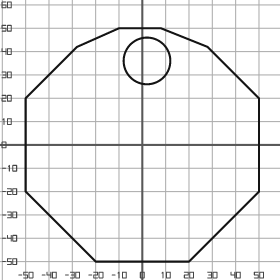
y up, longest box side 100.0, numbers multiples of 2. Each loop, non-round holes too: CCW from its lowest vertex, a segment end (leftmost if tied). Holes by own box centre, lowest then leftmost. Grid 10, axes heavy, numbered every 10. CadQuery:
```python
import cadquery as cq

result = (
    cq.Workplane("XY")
    .moveTo(-20.0, -50.0)
    .lineTo(20.0, -50.0)
    .lineTo(50.0, -20.0)
    .lineTo(50.0, 20.0)
    .lineTo(28.0, 42.0)
    .lineTo(8.0, 50.0)
    .lineTo(-10.0, 50.0)
    .lineTo(-28.0, 42.0)
    .lineTo(-50.0, 20.0)
    .lineTo(-50.0, -20.0)
    .close()
    .moveTo(2.0, 36.0)
    .circle(10.0)
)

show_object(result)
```